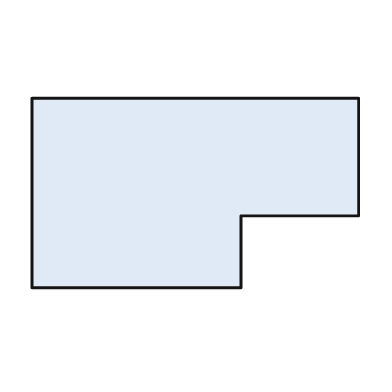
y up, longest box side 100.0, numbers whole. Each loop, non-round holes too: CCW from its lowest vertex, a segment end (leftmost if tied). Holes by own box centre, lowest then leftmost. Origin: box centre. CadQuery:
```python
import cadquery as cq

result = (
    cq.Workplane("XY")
    .moveTo(-50.0, -29.0)
    .lineTo(14.0, -29.0)
    .lineTo(14.0, -7.0)
    .lineTo(50.0, -7.0)
    .lineTo(50.0, 29.0)
    .lineTo(-50.0, 29.0)
    .close()
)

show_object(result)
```